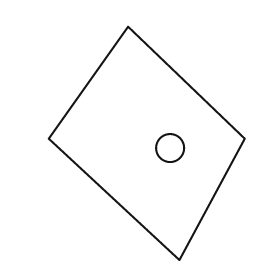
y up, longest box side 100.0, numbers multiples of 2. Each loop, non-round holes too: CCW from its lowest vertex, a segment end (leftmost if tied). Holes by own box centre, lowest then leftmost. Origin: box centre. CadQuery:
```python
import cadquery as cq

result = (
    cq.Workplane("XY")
    .moveTo(14.0, -50.0)
    .lineTo(42.0, 2.0)
    .lineTo(-8.0, 50.0)
    .lineTo(-42.0, 2.0)
    .close()
    .moveTo(10.0, -2.0)
    .circle(6.0)
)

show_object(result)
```